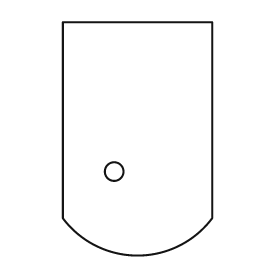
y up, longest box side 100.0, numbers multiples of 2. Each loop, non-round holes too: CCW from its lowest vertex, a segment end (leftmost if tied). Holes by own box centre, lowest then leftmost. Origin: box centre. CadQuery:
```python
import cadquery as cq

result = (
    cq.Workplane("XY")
    .moveTo(-32.0, -34.0)
    .threePointArc((0.0, -50.0), (32.0, -34.0))
    .lineTo(32.0, 50.0)
    .lineTo(-32.0, 50.0)
    .close()
    .moveTo(-10.0, -14.0)
    .circle(4.0)
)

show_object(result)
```